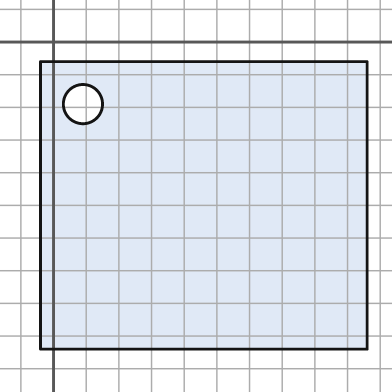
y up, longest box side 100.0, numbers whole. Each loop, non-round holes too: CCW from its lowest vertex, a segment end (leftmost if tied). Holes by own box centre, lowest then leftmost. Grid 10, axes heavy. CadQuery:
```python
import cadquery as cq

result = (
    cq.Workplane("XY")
    .moveTo(-4.0, -94.0)
    .lineTo(96.0, -94.0)
    .lineTo(96.0, -6.0)
    .lineTo(-4.0, -6.0)
    .close()
    .moveTo(9.0, -19.0)
    .circle(6.0)
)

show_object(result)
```